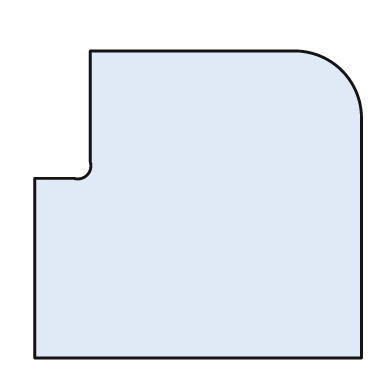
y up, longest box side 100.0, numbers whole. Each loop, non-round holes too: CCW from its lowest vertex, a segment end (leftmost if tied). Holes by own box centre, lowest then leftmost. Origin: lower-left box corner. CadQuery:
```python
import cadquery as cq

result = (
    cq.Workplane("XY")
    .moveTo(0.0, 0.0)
    .lineTo(100.0, 0.0)
    .lineTo(100.0, 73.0)
    .threePointArc((94.0, 88.0), (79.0, 94.0))
    .lineTo(17.0, 94.0)
    .lineTo(17.0, 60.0)
    .threePointArc((16.0, 56.0), (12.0, 55.0))
    .lineTo(0.0, 55.0)
    .close()
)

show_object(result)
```